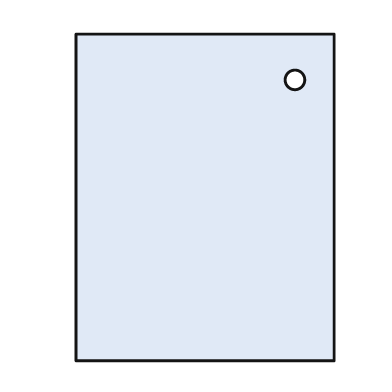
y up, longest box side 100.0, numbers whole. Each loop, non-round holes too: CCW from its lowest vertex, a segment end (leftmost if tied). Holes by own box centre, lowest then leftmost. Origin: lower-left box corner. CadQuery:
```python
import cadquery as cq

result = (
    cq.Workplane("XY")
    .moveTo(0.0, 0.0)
    .lineTo(79.0, 0.0)
    .lineTo(79.0, 100.0)
    .lineTo(0.0, 100.0)
    .close()
    .moveTo(67.0, 86.0)
    .circle(3.0)
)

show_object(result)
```